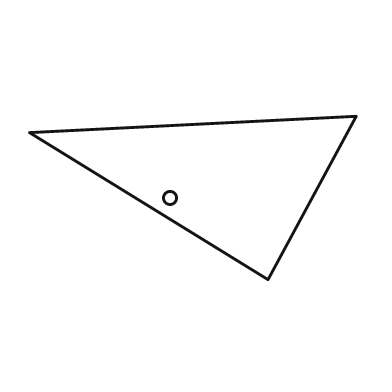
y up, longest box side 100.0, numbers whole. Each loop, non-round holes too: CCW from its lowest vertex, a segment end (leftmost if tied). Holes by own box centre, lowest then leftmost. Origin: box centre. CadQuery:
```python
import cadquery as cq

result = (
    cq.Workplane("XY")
    .moveTo(23.0, -25.0)
    .lineTo(50.0, 25.0)
    .lineTo(-50.0, 20.0)
    .close()
    .moveTo(-7.0, 0.0)
    .circle(2.0)
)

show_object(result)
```